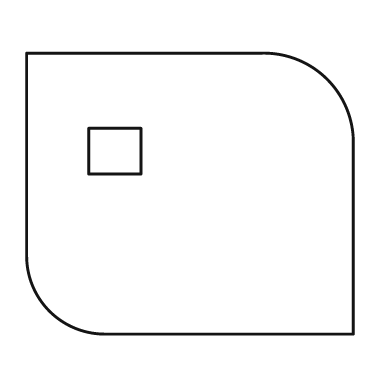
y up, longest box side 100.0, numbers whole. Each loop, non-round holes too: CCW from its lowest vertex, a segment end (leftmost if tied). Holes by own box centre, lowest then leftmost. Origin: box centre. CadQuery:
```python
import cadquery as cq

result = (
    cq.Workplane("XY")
    .moveTo(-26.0, -43.0)
    .lineTo(50.0, -43.0)
    .lineTo(50.0, 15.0)
    .threePointArc((42.0, 35.0), (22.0, 43.0))
    .lineTo(-50.0, 43.0)
    .lineTo(-50.0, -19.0)
    .threePointArc((-43.0, -36.0), (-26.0, -43.0))
    .close()
    .moveTo(-31.0, 6.0)
    .lineTo(-15.0, 6.0)
    .lineTo(-15.0, 20.0)
    .lineTo(-31.0, 20.0)
    .close()
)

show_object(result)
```